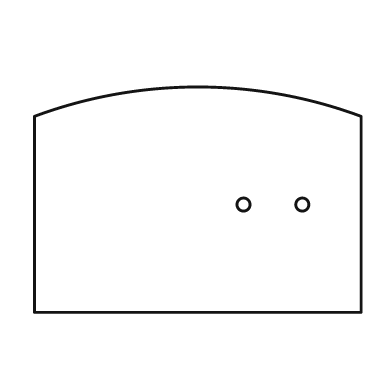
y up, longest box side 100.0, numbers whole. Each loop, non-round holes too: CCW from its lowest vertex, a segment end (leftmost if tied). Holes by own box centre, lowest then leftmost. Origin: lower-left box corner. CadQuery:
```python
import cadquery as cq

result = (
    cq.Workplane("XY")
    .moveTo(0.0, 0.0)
    .lineTo(100.0, 0.0)
    .lineTo(100.0, 60.0)
    .threePointArc((50.0, 69.0), (0.0, 60.0))
    .close()
    .moveTo(64.0, 33.0)
    .circle(2.0)
    .moveTo(82.0, 33.0)
    .circle(2.0)
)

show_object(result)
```